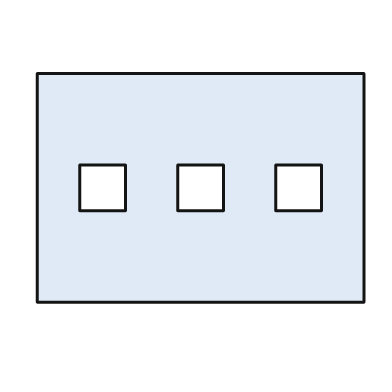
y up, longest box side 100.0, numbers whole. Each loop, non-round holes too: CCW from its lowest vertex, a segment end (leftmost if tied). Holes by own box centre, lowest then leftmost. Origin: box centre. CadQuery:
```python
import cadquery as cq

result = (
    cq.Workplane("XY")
    .moveTo(-50.0, -35.0)
    .lineTo(50.0, -35.0)
    .lineTo(50.0, 35.0)
    .lineTo(-50.0, 35.0)
    .close()
    .moveTo(-37.0, -7.0)
    .lineTo(-23.0, -7.0)
    .lineTo(-23.0, 7.0)
    .lineTo(-37.0, 7.0)
    .close()
    .moveTo(-7.0, -7.0)
    .lineTo(7.0, -7.0)
    .lineTo(7.0, 7.0)
    .lineTo(-7.0, 7.0)
    .close()
    .moveTo(23.0, -7.0)
    .lineTo(37.0, -7.0)
    .lineTo(37.0, 7.0)
    .lineTo(23.0, 7.0)
    .close()
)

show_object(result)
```